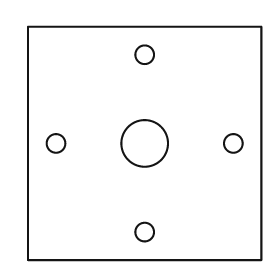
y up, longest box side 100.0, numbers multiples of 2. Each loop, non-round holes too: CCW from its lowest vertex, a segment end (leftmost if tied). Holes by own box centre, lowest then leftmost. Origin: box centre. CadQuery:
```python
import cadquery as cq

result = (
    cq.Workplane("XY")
    .moveTo(-50.0, -50.0)
    .lineTo(50.0, -50.0)
    .lineTo(50.0, 50.0)
    .lineTo(-50.0, 50.0)
    .close()
    .moveTo(0.0, -38.0)
    .circle(4.0)
    .moveTo(-38.0, 0.0)
    .circle(4.0)
    .moveTo(0.0, 0.0)
    .circle(10.0)
    .moveTo(38.0, 0.0)
    .circle(4.0)
    .moveTo(0.0, 38.0)
    .circle(4.0)
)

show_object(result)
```